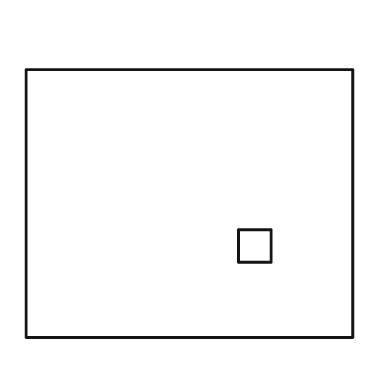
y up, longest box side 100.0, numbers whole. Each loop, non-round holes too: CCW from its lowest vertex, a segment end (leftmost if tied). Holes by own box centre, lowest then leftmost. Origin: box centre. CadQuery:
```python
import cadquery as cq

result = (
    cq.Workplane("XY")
    .moveTo(-50.0, -41.0)
    .lineTo(50.0, -41.0)
    .lineTo(50.0, 41.0)
    .lineTo(-50.0, 41.0)
    .close()
    .moveTo(15.0, -18.0)
    .lineTo(25.0, -18.0)
    .lineTo(25.0, -8.0)
    .lineTo(15.0, -8.0)
    .close()
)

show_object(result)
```